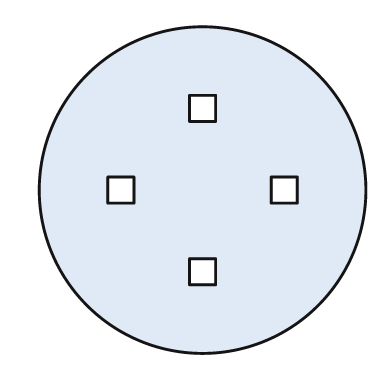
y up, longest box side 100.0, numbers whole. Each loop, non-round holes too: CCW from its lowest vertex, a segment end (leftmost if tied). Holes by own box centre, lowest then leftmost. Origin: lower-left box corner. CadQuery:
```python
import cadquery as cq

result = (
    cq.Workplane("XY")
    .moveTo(50.0, 50.0)
    .circle(50.0)
    .moveTo(46.0, 21.0)
    .lineTo(54.0, 21.0)
    .lineTo(54.0, 29.0)
    .lineTo(46.0, 29.0)
    .close()
    .moveTo(21.0, 46.0)
    .lineTo(29.0, 46.0)
    .lineTo(29.0, 54.0)
    .lineTo(21.0, 54.0)
    .close()
    .moveTo(71.0, 46.0)
    .lineTo(79.0, 46.0)
    .lineTo(79.0, 54.0)
    .lineTo(71.0, 54.0)
    .close()
    .moveTo(46.0, 71.0)
    .lineTo(54.0, 71.0)
    .lineTo(54.0, 79.0)
    .lineTo(46.0, 79.0)
    .close()
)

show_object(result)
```